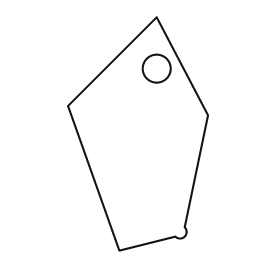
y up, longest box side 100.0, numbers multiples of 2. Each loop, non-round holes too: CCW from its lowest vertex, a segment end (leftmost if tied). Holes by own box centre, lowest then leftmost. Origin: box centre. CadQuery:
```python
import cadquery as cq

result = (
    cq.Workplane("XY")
    .moveTo(-8.0, -50.0)
    .lineTo(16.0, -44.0)
    .threePointArc((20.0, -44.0), (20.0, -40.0))
    .lineTo(30.0, 8.0)
    .lineTo(8.0, 50.0)
    .lineTo(-30.0, 12.0)
    .close()
    .moveTo(8.0, 28.0)
    .circle(6.0)
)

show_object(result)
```